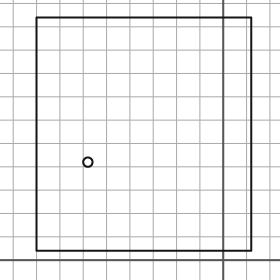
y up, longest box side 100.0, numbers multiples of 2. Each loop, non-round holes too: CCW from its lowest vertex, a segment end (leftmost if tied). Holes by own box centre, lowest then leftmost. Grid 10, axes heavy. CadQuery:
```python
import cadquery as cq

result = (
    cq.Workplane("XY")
    .moveTo(-80.0, 4.0)
    .lineTo(12.0, 4.0)
    .lineTo(12.0, 104.0)
    .lineTo(-80.0, 104.0)
    .close()
    .moveTo(-58.0, 42.0)
    .circle(2.0)
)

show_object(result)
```